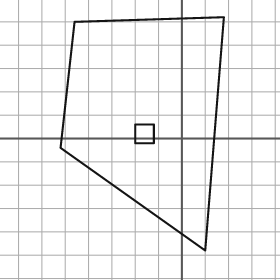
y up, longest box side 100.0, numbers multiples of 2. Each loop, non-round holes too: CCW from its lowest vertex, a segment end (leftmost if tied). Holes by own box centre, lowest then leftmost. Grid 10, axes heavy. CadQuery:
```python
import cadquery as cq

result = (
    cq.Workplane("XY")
    .moveTo(10.0, -48.0)
    .lineTo(18.0, 52.0)
    .lineTo(-46.0, 50.0)
    .lineTo(-52.0, -4.0)
    .close()
    .moveTo(-20.0, -2.0)
    .lineTo(-12.0, -2.0)
    .lineTo(-12.0, 6.0)
    .lineTo(-20.0, 6.0)
    .close()
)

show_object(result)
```